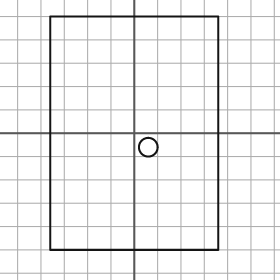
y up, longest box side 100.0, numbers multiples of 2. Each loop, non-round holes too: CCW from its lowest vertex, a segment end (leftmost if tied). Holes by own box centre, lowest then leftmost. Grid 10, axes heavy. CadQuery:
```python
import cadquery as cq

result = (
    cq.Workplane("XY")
    .moveTo(-36.0, -50.0)
    .lineTo(36.0, -50.0)
    .lineTo(36.0, 50.0)
    .lineTo(-36.0, 50.0)
    .close()
    .moveTo(6.0, -6.0)
    .circle(4.0)
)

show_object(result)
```